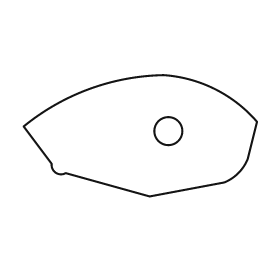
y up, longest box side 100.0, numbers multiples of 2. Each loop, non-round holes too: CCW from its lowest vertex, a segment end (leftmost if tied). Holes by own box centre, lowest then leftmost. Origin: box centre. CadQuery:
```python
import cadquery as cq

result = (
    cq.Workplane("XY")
    .moveTo(4.0, -26.0)
    .lineTo(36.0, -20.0)
    .threePointArc((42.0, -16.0), (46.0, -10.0))
    .lineTo(50.0, 6.0)
    .threePointArc((32.0, 20.0), (10.0, 26.0))
    .threePointArc((-22.0, 20.0), (-50.0, 4.0))
    .lineTo(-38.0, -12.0)
    .threePointArc((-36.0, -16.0), (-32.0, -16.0))
    .close()
    .moveTo(12.0, 2.0)
    .circle(6.0)
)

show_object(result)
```